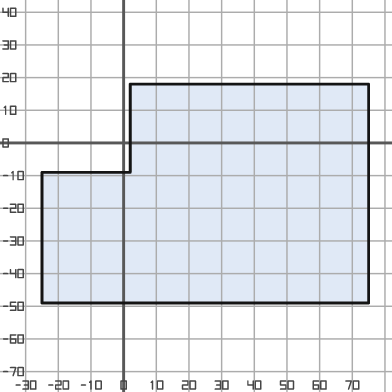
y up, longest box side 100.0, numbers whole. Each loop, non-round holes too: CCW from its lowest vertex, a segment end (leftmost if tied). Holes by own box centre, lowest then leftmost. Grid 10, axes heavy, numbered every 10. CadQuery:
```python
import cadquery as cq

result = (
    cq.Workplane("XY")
    .moveTo(-25.0, -49.0)
    .lineTo(75.0, -49.0)
    .lineTo(75.0, 18.0)
    .lineTo(2.0, 18.0)
    .lineTo(2.0, -9.0)
    .lineTo(-25.0, -9.0)
    .close()
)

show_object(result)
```